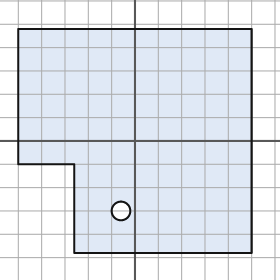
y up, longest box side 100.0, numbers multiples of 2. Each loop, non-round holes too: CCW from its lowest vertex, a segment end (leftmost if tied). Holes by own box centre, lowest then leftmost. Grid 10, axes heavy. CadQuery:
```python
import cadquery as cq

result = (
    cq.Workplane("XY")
    .moveTo(-26.0, -48.0)
    .lineTo(50.0, -48.0)
    .lineTo(50.0, 48.0)
    .lineTo(-50.0, 48.0)
    .lineTo(-50.0, -10.0)
    .lineTo(-26.0, -10.0)
    .close()
    .moveTo(-6.0, -30.0)
    .circle(4.0)
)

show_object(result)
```